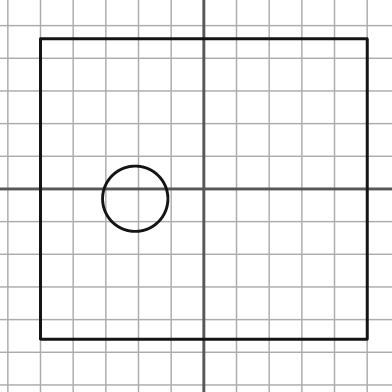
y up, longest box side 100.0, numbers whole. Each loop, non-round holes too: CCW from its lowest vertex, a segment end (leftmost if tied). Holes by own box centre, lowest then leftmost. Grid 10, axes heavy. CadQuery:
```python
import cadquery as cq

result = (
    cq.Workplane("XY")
    .moveTo(-50.0, -46.0)
    .lineTo(50.0, -46.0)
    .lineTo(50.0, 46.0)
    .lineTo(-50.0, 46.0)
    .close()
    .moveTo(-21.0, -3.0)
    .circle(10.0)
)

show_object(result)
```